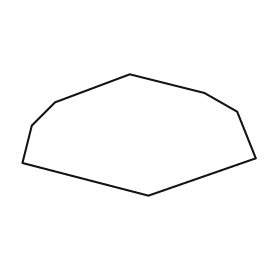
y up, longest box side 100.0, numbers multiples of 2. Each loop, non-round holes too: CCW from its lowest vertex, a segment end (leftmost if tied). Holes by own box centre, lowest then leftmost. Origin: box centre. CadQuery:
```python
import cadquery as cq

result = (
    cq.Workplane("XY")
    .moveTo(4.0, -26.0)
    .lineTo(50.0, -10.0)
    .lineTo(42.0, 10.0)
    .lineTo(28.0, 18.0)
    .lineTo(-4.0, 26.0)
    .lineTo(-36.0, 14.0)
    .lineTo(-46.0, 4.0)
    .lineTo(-50.0, -12.0)
    .close()
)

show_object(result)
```